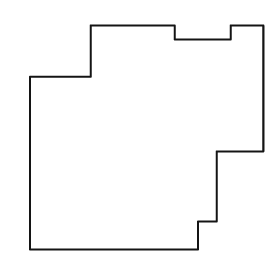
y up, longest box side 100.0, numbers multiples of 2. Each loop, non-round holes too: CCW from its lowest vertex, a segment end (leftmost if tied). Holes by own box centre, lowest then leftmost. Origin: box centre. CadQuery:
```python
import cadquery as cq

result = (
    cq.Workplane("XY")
    .moveTo(-50.0, -48.0)
    .lineTo(22.0, -48.0)
    .lineTo(22.0, -36.0)
    .lineTo(30.0, -36.0)
    .lineTo(30.0, -6.0)
    .lineTo(50.0, -6.0)
    .lineTo(50.0, 48.0)
    .lineTo(36.0, 48.0)
    .lineTo(36.0, 42.0)
    .lineTo(12.0, 42.0)
    .lineTo(12.0, 48.0)
    .lineTo(-24.0, 48.0)
    .lineTo(-24.0, 26.0)
    .lineTo(-50.0, 26.0)
    .close()
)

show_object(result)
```